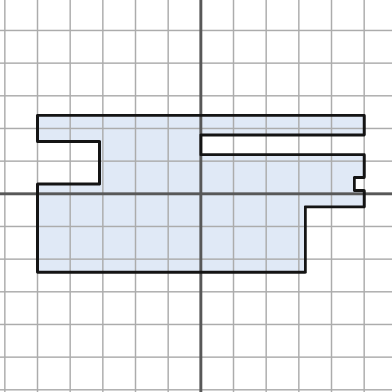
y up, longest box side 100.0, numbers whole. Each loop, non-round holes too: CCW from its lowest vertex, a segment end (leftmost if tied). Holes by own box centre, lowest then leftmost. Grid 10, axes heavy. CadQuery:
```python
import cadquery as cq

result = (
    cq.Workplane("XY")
    .moveTo(-50.0, -24.0)
    .lineTo(32.0, -24.0)
    .lineTo(32.0, -4.0)
    .lineTo(50.0, -4.0)
    .lineTo(50.0, 1.0)
    .lineTo(47.0, 1.0)
    .lineTo(47.0, 5.0)
    .lineTo(50.0, 5.0)
    .lineTo(50.0, 12.0)
    .lineTo(0.0, 12.0)
    .lineTo(0.0, 18.0)
    .lineTo(50.0, 18.0)
    .lineTo(50.0, 24.0)
    .lineTo(-50.0, 24.0)
    .lineTo(-50.0, 16.0)
    .lineTo(-31.0, 16.0)
    .lineTo(-31.0, 3.0)
    .lineTo(-50.0, 3.0)
    .close()
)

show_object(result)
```